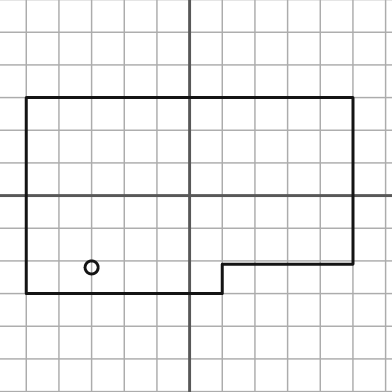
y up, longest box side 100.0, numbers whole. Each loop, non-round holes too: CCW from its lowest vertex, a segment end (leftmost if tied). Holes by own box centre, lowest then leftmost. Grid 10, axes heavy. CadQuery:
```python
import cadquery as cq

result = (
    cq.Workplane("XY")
    .moveTo(-50.0, -30.0)
    .lineTo(10.0, -30.0)
    .lineTo(10.0, -21.0)
    .lineTo(50.0, -21.0)
    .lineTo(50.0, 30.0)
    .lineTo(-50.0, 30.0)
    .close()
    .moveTo(-30.0, -22.0)
    .circle(2.0)
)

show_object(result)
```